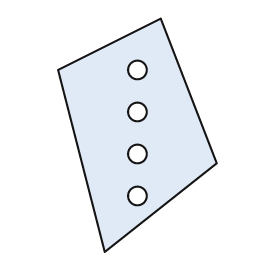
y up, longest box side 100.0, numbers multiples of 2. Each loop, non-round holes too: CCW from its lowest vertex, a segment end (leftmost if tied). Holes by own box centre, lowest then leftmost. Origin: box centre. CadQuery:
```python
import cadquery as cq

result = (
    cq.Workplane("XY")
    .moveTo(-14.0, -50.0)
    .lineTo(34.0, -12.0)
    .lineTo(10.0, 50.0)
    .lineTo(-34.0, 28.0)
    .close()
    .moveTo(0.0, -26.0)
    .circle(4.0)
    .moveTo(0.0, -8.0)
    .circle(4.0)
    .moveTo(0.0, 10.0)
    .circle(4.0)
    .moveTo(0.0, 28.0)
    .circle(4.0)
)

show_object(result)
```